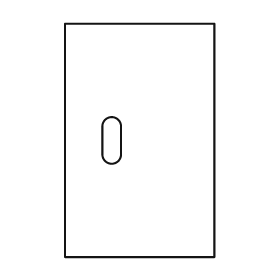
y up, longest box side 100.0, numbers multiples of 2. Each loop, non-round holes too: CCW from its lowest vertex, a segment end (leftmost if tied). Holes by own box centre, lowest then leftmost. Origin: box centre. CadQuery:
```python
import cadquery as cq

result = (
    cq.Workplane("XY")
    .moveTo(-32.0, -50.0)
    .lineTo(32.0, -50.0)
    .lineTo(32.0, 50.0)
    .lineTo(-32.0, 50.0)
    .close()
    .moveTo(-16.0, -6.0)
    .threePointArc((-12.0, -10.0), (-8.0, -6.0))
    .lineTo(-8.0, 6.0)
    .threePointArc((-12.0, 10.0), (-16.0, 6.0))
    .close()
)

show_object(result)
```